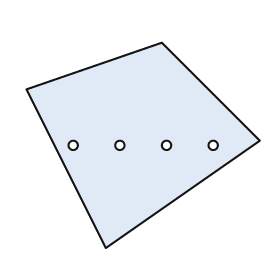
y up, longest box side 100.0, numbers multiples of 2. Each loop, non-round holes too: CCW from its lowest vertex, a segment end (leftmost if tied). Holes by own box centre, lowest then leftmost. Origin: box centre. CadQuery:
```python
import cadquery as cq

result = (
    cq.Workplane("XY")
    .moveTo(-16.0, -44.0)
    .lineTo(50.0, 2.0)
    .lineTo(8.0, 44.0)
    .lineTo(-50.0, 24.0)
    .close()
    .moveTo(-30.0, 0.0)
    .circle(2.0)
    .moveTo(-10.0, 0.0)
    .circle(2.0)
    .moveTo(10.0, 0.0)
    .circle(2.0)
    .moveTo(30.0, 0.0)
    .circle(2.0)
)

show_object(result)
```